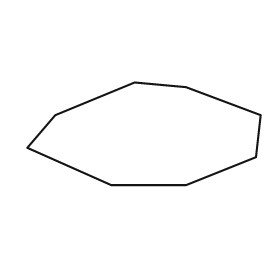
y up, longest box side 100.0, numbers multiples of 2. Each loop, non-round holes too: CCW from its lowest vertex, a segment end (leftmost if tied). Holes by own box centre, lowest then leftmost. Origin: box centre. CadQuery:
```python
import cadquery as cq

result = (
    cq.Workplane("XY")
    .moveTo(-14.0, -22.0)
    .lineTo(18.0, -22.0)
    .lineTo(48.0, -10.0)
    .lineTo(50.0, 8.0)
    .lineTo(18.0, 20.0)
    .lineTo(-4.0, 22.0)
    .lineTo(-38.0, 8.0)
    .lineTo(-50.0, -6.0)
    .close()
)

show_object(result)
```